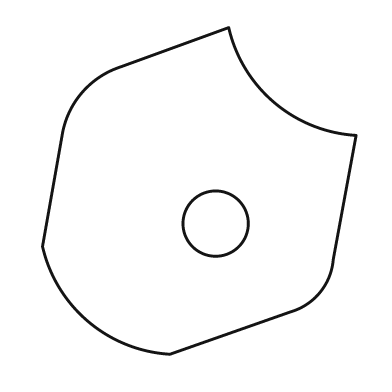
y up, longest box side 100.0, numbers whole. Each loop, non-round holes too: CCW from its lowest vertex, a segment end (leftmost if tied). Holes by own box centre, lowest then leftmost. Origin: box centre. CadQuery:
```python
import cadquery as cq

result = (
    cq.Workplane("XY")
    .moveTo(-9.0, -50.0)
    .lineTo(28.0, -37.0)
    .threePointArc((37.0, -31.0), (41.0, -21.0))
    .lineTo(48.0, 17.0)
    .threePointArc((23.0, 27.0), (9.0, 50.0))
    .lineTo(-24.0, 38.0)
    .threePointArc((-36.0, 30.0), (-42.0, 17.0))
    .lineTo(-48.0, -17.0)
    .threePointArc((-34.0, -40.0), (-9.0, -50.0))
    .close()
    .moveTo(5.0, -10.0)
    .circle(10.0)
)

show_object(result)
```